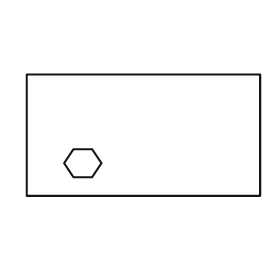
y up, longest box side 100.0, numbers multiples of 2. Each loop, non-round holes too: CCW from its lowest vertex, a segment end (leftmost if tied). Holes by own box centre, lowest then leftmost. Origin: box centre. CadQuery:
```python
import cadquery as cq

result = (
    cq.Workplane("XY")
    .moveTo(-50.0, -26.0)
    .lineTo(50.0, -26.0)
    .lineTo(50.0, 26.0)
    .lineTo(-50.0, 26.0)
    .close()
    .moveTo(-30.0, -18.0)
    .lineTo(-22.0, -18.0)
    .lineTo(-18.0, -12.0)
    .lineTo(-22.0, -6.0)
    .lineTo(-30.0, -6.0)
    .lineTo(-34.0, -12.0)
    .close()
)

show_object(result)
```